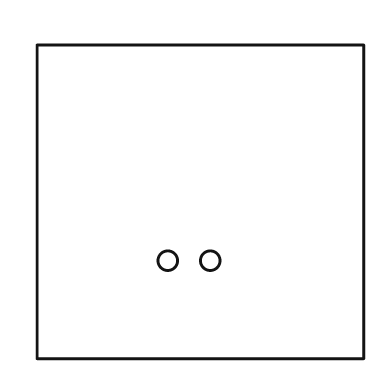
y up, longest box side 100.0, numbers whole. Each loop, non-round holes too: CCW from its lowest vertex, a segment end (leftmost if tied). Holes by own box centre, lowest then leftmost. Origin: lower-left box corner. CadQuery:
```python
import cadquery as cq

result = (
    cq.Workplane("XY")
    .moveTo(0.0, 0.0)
    .lineTo(100.0, 0.0)
    .lineTo(100.0, 96.0)
    .lineTo(0.0, 96.0)
    .close()
    .moveTo(40.0, 30.0)
    .circle(3.0)
    .moveTo(53.0, 30.0)
    .circle(3.0)
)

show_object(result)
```